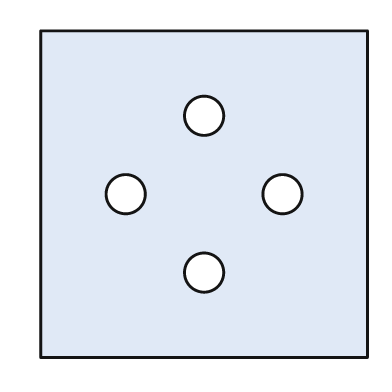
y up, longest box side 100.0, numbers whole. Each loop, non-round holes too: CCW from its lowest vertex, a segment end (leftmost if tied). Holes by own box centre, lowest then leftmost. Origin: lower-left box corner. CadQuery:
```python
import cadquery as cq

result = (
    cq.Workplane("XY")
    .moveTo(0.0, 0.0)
    .lineTo(100.0, 0.0)
    .lineTo(100.0, 100.0)
    .lineTo(0.0, 100.0)
    .close()
    .moveTo(50.0, 26.0)
    .circle(6.0)
    .moveTo(26.0, 50.0)
    .circle(6.0)
    .moveTo(74.0, 50.0)
    .circle(6.0)
    .moveTo(50.0, 74.0)
    .circle(6.0)
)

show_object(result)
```